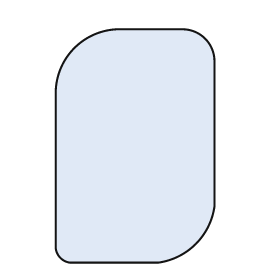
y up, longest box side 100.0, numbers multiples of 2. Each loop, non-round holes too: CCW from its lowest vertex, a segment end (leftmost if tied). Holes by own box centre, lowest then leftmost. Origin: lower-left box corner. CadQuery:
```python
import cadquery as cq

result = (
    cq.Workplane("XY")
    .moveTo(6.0, 0.0)
    .lineTo(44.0, 0.0)
    .threePointArc((60.0, 8.0), (68.0, 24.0))
    .lineTo(68.0, 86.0)
    .threePointArc((64.0, 96.0), (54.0, 100.0))
    .lineTo(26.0, 100.0)
    .threePointArc((8.0, 92.0), (0.0, 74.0))
    .lineTo(0.0, 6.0)
    .threePointArc((2.0, 2.0), (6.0, 0.0))
    .close()
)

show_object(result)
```